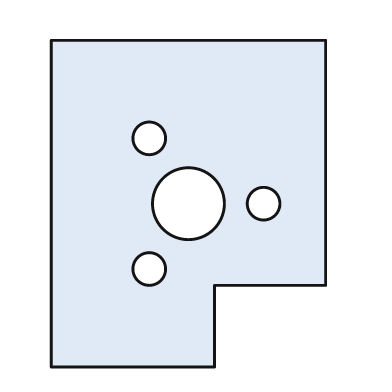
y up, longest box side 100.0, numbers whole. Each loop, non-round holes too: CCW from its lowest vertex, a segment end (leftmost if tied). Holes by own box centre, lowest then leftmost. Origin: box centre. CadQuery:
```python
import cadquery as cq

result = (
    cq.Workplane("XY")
    .moveTo(-42.0, -50.0)
    .lineTo(8.0, -50.0)
    .lineTo(8.0, -25.0)
    .lineTo(42.0, -25.0)
    .lineTo(42.0, 50.0)
    .lineTo(-42.0, 50.0)
    .close()
    .moveTo(-12.0, -20.0)
    .circle(5.0)
    .moveTo(0.0, 0.0)
    .circle(11.0)
    .moveTo(23.0, 0.0)
    .circle(5.0)
    .moveTo(-12.0, 20.0)
    .circle(5.0)
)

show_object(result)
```